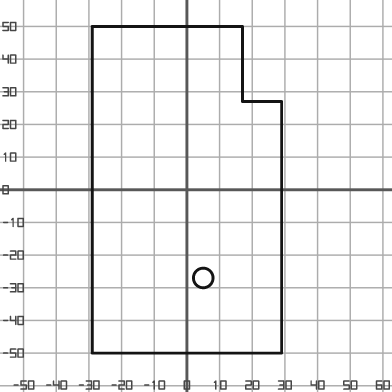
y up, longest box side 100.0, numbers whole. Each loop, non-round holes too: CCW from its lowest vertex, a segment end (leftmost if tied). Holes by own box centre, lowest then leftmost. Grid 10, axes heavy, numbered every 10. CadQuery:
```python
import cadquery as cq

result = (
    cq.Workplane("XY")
    .moveTo(-29.0, -50.0)
    .lineTo(29.0, -50.0)
    .lineTo(29.0, 27.0)
    .lineTo(17.0, 27.0)
    .lineTo(17.0, 50.0)
    .lineTo(-29.0, 50.0)
    .close()
    .moveTo(5.0, -27.0)
    .circle(3.0)
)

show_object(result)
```